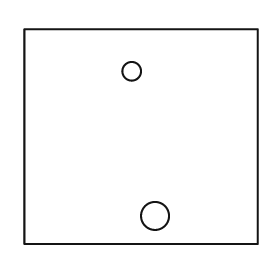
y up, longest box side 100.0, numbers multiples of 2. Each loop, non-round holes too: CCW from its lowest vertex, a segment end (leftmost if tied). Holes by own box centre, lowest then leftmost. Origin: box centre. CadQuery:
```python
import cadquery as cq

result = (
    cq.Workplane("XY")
    .moveTo(-50.0, -46.0)
    .lineTo(50.0, -46.0)
    .lineTo(50.0, 46.0)
    .lineTo(-50.0, 46.0)
    .close()
    .moveTo(6.0, -34.0)
    .circle(6.0)
    .moveTo(-4.0, 28.0)
    .circle(4.0)
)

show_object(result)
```